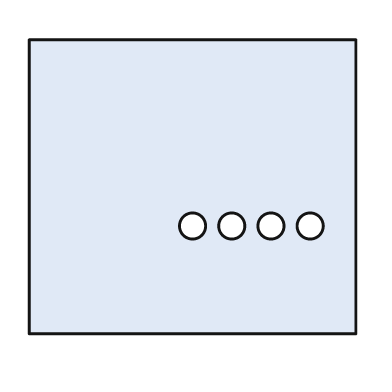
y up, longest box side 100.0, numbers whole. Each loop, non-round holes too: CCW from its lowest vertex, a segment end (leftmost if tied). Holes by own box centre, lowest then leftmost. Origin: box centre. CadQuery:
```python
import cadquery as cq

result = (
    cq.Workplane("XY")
    .moveTo(-50.0, -45.0)
    .lineTo(50.0, -45.0)
    .lineTo(50.0, 45.0)
    .lineTo(-50.0, 45.0)
    .close()
    .moveTo(0.0, -12.0)
    .circle(4.0)
    .moveTo(12.0, -12.0)
    .circle(4.0)
    .moveTo(24.0, -12.0)
    .circle(4.0)
    .moveTo(36.0, -12.0)
    .circle(4.0)
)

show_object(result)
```